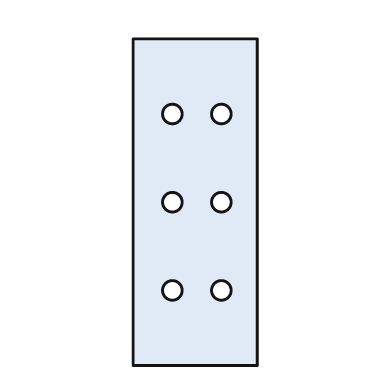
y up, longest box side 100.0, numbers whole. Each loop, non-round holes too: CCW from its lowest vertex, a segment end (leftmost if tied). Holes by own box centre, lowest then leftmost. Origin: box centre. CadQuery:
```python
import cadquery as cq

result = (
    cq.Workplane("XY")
    .moveTo(-19.0, -50.0)
    .lineTo(19.0, -50.0)
    .lineTo(19.0, 50.0)
    .lineTo(-19.0, 50.0)
    .close()
    .moveTo(-7.0, -27.0)
    .circle(3.0)
    .moveTo(8.0, -27.0)
    .circle(3.0)
    .moveTo(-7.0, 0.0)
    .circle(3.0)
    .moveTo(8.0, 0.0)
    .circle(3.0)
    .moveTo(-7.0, 27.0)
    .circle(3.0)
    .moveTo(8.0, 27.0)
    .circle(3.0)
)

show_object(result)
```